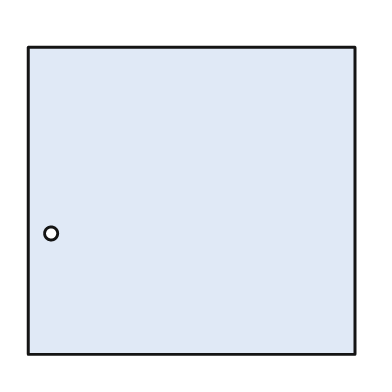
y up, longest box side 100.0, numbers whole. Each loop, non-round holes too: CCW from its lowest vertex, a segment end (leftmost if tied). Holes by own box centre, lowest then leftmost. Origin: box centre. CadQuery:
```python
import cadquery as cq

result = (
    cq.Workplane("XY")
    .moveTo(-50.0, -47.0)
    .lineTo(50.0, -47.0)
    .lineTo(50.0, 47.0)
    .lineTo(-50.0, 47.0)
    .close()
    .moveTo(-43.0, -10.0)
    .circle(2.0)
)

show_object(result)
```